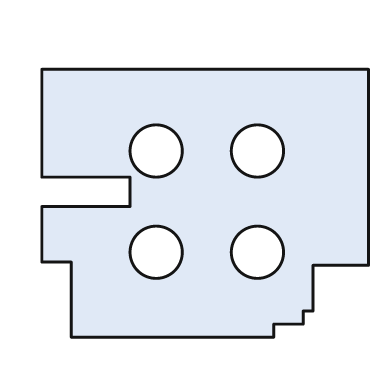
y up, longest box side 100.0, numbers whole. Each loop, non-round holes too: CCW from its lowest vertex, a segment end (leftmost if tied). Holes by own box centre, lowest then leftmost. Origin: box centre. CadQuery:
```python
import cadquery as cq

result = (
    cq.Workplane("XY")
    .moveTo(-41.0, -41.0)
    .lineTo(21.0, -41.0)
    .lineTo(21.0, -37.0)
    .lineTo(30.0, -37.0)
    .lineTo(30.0, -33.0)
    .lineTo(33.0, -33.0)
    .lineTo(33.0, -19.0)
    .lineTo(50.0, -19.0)
    .lineTo(50.0, 41.0)
    .lineTo(-50.0, 41.0)
    .lineTo(-50.0, 8.0)
    .lineTo(-23.0, 8.0)
    .lineTo(-23.0, -1.0)
    .lineTo(-50.0, -1.0)
    .lineTo(-50.0, -18.0)
    .lineTo(-41.0, -18.0)
    .close()
    .moveTo(-15.0, -15.0)
    .circle(8.0)
    .moveTo(16.0, -15.0)
    .circle(8.0)
    .moveTo(-15.0, 16.0)
    .circle(8.0)
    .moveTo(16.0, 16.0)
    .circle(8.0)
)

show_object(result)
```